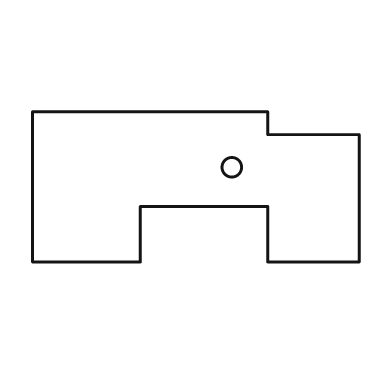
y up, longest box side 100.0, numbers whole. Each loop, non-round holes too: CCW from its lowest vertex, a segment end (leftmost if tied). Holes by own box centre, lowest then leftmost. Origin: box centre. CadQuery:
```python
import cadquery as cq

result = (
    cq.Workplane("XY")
    .moveTo(-50.0, -23.0)
    .lineTo(-17.0, -23.0)
    .lineTo(-17.0, -6.0)
    .lineTo(22.0, -6.0)
    .lineTo(22.0, -23.0)
    .lineTo(50.0, -23.0)
    .lineTo(50.0, 16.0)
    .lineTo(22.0, 16.0)
    .lineTo(22.0, 23.0)
    .lineTo(-50.0, 23.0)
    .close()
    .moveTo(11.0, 6.0)
    .circle(3.0)
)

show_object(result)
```